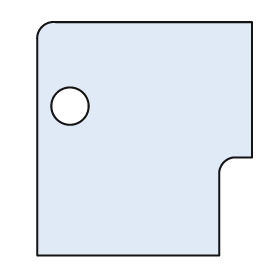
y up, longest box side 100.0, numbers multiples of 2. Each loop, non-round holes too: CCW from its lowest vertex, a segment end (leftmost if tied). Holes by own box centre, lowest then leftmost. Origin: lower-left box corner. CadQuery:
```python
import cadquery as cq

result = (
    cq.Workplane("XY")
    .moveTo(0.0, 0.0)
    .lineTo(78.0, 0.0)
    .lineTo(78.0, 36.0)
    .threePointArc((80.0, 40.0), (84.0, 42.0))
    .lineTo(92.0, 42.0)
    .lineTo(92.0, 100.0)
    .lineTo(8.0, 100.0)
    .threePointArc((2.0, 98.0), (0.0, 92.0))
    .close()
    .moveTo(14.0, 64.0)
    .circle(8.0)
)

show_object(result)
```